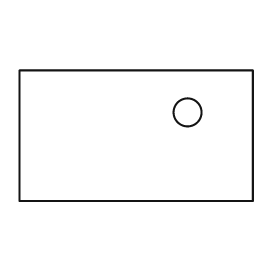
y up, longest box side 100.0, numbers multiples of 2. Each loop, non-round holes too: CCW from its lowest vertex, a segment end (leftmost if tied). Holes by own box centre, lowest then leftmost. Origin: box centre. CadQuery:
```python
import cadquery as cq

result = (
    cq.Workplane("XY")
    .moveTo(-50.0, -28.0)
    .lineTo(50.0, -28.0)
    .lineTo(50.0, 28.0)
    .lineTo(-50.0, 28.0)
    .close()
    .moveTo(22.0, 10.0)
    .circle(6.0)
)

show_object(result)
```